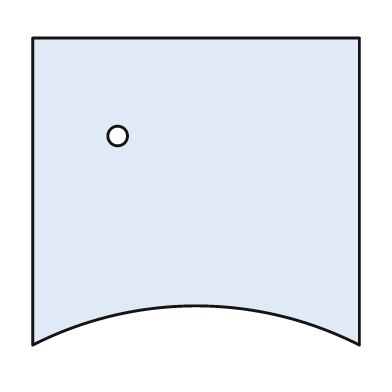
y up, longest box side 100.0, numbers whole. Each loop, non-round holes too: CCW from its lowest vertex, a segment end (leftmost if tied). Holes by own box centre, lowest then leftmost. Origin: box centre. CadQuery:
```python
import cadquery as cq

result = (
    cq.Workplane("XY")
    .moveTo(-50.0, -47.0)
    .threePointArc((0.0, -35.0), (50.0, -47.0))
    .lineTo(50.0, 47.0)
    .lineTo(-50.0, 47.0)
    .close()
    .moveTo(-24.0, 17.0)
    .circle(3.0)
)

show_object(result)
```